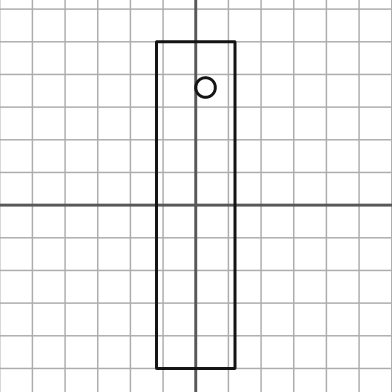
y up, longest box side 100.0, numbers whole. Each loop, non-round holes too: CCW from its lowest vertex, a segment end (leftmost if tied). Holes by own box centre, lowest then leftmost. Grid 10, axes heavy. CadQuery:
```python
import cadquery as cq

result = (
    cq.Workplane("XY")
    .moveTo(-12.0, -50.0)
    .lineTo(12.0, -50.0)
    .lineTo(12.0, 50.0)
    .lineTo(-12.0, 50.0)
    .close()
    .moveTo(3.0, 36.0)
    .circle(3.0)
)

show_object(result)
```